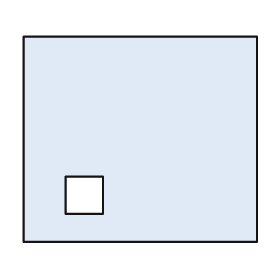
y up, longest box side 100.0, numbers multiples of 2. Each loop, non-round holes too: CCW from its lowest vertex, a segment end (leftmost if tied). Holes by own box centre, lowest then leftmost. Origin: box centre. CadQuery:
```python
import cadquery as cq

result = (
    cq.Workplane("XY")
    .moveTo(-50.0, -44.0)
    .lineTo(50.0, -44.0)
    .lineTo(50.0, 44.0)
    .lineTo(-50.0, 44.0)
    .close()
    .moveTo(-32.0, -32.0)
    .lineTo(-16.0, -32.0)
    .lineTo(-16.0, -16.0)
    .lineTo(-32.0, -16.0)
    .close()
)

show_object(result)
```